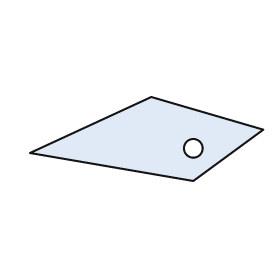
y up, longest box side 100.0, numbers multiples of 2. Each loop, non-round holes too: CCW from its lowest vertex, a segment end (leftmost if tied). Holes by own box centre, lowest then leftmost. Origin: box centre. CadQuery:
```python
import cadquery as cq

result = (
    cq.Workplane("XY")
    .moveTo(20.0, -18.0)
    .lineTo(50.0, 4.0)
    .lineTo(2.0, 18.0)
    .lineTo(-50.0, -6.0)
    .close()
    .moveTo(20.0, -4.0)
    .circle(4.0)
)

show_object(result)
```